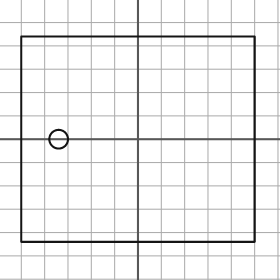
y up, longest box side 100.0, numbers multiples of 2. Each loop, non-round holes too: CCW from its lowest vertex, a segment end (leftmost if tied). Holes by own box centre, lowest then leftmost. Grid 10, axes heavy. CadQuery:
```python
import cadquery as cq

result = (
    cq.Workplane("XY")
    .moveTo(-50.0, -44.0)
    .lineTo(50.0, -44.0)
    .lineTo(50.0, 44.0)
    .lineTo(-50.0, 44.0)
    .close()
    .moveTo(-34.0, 0.0)
    .circle(4.0)
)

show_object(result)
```